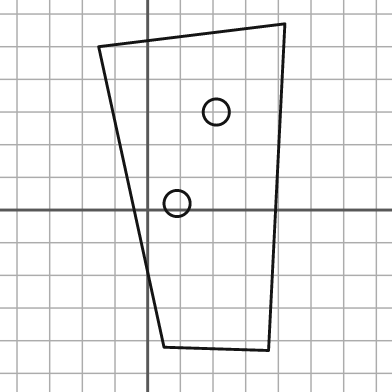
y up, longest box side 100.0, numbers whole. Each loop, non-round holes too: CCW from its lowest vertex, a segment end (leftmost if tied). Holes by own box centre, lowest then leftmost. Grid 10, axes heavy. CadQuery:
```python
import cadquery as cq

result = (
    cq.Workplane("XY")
    .moveTo(37.0, -43.0)
    .lineTo(42.0, 57.0)
    .lineTo(-15.0, 50.0)
    .lineTo(5.0, -42.0)
    .close()
    .moveTo(9.0, 2.0)
    .circle(4.0)
    .moveTo(21.0, 30.0)
    .circle(4.0)
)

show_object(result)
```